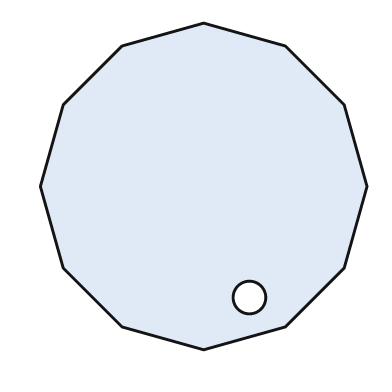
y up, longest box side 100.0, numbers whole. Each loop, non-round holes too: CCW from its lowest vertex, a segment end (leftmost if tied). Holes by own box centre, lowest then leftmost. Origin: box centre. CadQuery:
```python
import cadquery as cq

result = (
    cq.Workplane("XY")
    .moveTo(0.0, -50.0)
    .lineTo(25.0, -43.0)
    .lineTo(43.0, -25.0)
    .lineTo(50.0, 0.0)
    .lineTo(43.0, 25.0)
    .lineTo(25.0, 43.0)
    .lineTo(0.0, 50.0)
    .lineTo(-25.0, 43.0)
    .lineTo(-43.0, 25.0)
    .lineTo(-50.0, 0.0)
    .lineTo(-43.0, -25.0)
    .lineTo(-25.0, -43.0)
    .close()
    .moveTo(14.0, -34.0)
    .circle(5.0)
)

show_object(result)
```